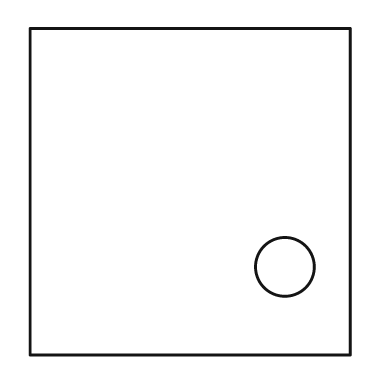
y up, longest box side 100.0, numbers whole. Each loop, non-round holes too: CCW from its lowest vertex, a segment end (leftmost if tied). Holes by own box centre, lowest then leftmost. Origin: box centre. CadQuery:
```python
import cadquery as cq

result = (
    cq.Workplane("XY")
    .moveTo(-49.0, -50.0)
    .lineTo(49.0, -50.0)
    .lineTo(49.0, 50.0)
    .lineTo(-49.0, 50.0)
    .close()
    .moveTo(29.0, -23.0)
    .circle(9.0)
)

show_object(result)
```